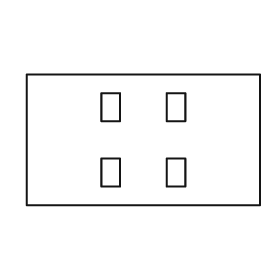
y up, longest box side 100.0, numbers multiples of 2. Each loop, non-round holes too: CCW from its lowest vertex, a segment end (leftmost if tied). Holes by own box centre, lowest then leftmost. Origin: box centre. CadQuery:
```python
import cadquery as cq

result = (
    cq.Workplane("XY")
    .moveTo(-50.0, -28.0)
    .lineTo(50.0, -28.0)
    .lineTo(50.0, 28.0)
    .lineTo(-50.0, 28.0)
    .close()
    .moveTo(-18.0, -20.0)
    .lineTo(-10.0, -20.0)
    .lineTo(-10.0, -8.0)
    .lineTo(-18.0, -8.0)
    .close()
    .moveTo(10.0, -20.0)
    .lineTo(18.0, -20.0)
    .lineTo(18.0, -8.0)
    .lineTo(10.0, -8.0)
    .close()
    .moveTo(-18.0, 8.0)
    .lineTo(-10.0, 8.0)
    .lineTo(-10.0, 20.0)
    .lineTo(-18.0, 20.0)
    .close()
    .moveTo(10.0, 8.0)
    .lineTo(18.0, 8.0)
    .lineTo(18.0, 20.0)
    .lineTo(10.0, 20.0)
    .close()
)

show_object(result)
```